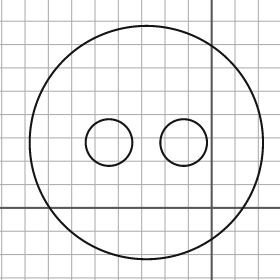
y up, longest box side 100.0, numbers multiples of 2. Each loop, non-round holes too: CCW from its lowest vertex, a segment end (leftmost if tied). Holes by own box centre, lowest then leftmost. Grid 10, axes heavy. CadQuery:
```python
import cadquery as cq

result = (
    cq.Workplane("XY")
    .moveTo(-28.0, 28.0)
    .circle(50.0)
    .moveTo(-44.0, 28.0)
    .circle(10.0)
    .moveTo(-12.0, 28.0)
    .circle(10.0)
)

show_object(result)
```